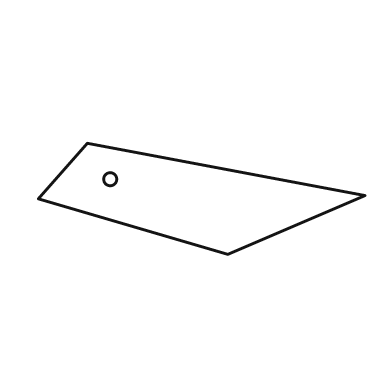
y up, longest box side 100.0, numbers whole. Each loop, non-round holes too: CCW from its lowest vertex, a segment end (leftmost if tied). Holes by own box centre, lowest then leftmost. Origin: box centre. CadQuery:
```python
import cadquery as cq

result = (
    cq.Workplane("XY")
    .moveTo(8.0, -17.0)
    .lineTo(50.0, 1.0)
    .lineTo(-35.0, 17.0)
    .lineTo(-50.0, 0.0)
    .close()
    .moveTo(-28.0, 6.0)
    .circle(2.0)
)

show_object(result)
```